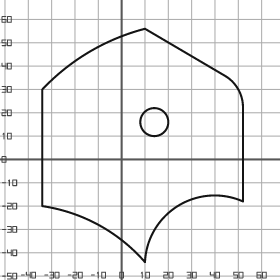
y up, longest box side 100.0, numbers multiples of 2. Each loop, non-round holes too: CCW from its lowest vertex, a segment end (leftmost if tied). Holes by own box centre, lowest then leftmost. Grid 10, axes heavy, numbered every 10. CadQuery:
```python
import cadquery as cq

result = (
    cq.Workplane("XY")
    .moveTo(10.0, -44.0)
    .threePointArc((24.0, -20.0), (52.0, -18.0))
    .lineTo(52.0, 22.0)
    .threePointArc((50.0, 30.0), (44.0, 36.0))
    .lineTo(10.0, 56.0)
    .threePointArc((-14.0, 46.0), (-34.0, 30.0))
    .lineTo(-34.0, -20.0)
    .threePointArc((-10.0, -28.0), (10.0, -44.0))
    .close()
    .moveTo(14.0, 16.0)
    .circle(6.0)
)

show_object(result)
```